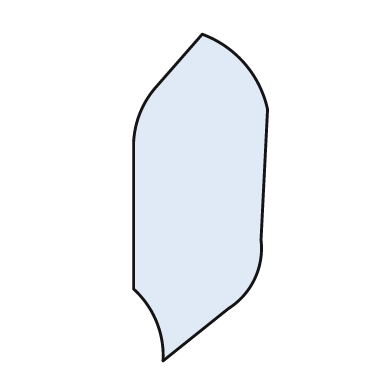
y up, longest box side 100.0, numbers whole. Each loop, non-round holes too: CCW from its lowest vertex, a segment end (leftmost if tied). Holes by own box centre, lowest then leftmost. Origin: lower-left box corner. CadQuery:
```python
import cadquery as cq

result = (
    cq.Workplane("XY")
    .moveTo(9.0, 0.0)
    .lineTo(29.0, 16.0)
    .threePointArc((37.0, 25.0), (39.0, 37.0))
    .lineTo(41.0, 77.0)
    .threePointArc((34.0, 91.0), (21.0, 100.0))
    .lineTo(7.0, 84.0)
    .threePointArc((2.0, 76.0), (0.0, 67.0))
    .lineTo(0.0, 22.0)
    .threePointArc((7.0, 12.0), (9.0, 0.0))
    .close()
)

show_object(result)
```